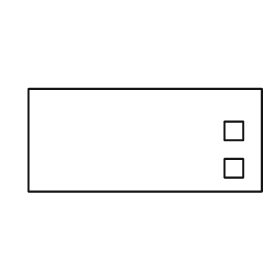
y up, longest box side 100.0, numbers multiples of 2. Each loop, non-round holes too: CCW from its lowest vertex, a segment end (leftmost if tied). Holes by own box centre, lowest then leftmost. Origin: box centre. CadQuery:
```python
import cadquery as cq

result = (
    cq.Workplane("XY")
    .moveTo(-50.0, -22.0)
    .lineTo(50.0, -22.0)
    .lineTo(50.0, 22.0)
    .lineTo(-50.0, 22.0)
    .close()
    .moveTo(34.0, -16.0)
    .lineTo(42.0, -16.0)
    .lineTo(42.0, -8.0)
    .lineTo(34.0, -8.0)
    .close()
    .moveTo(34.0, 0.0)
    .lineTo(42.0, 0.0)
    .lineTo(42.0, 8.0)
    .lineTo(34.0, 8.0)
    .close()
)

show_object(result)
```